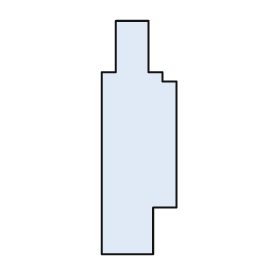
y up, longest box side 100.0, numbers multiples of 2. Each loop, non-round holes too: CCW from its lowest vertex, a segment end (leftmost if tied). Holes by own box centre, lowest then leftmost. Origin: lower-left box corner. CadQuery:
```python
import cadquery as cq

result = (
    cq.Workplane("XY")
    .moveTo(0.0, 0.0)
    .lineTo(22.0, 0.0)
    .lineTo(22.0, 20.0)
    .lineTo(32.0, 20.0)
    .lineTo(32.0, 74.0)
    .lineTo(26.0, 74.0)
    .lineTo(26.0, 78.0)
    .lineTo(20.0, 78.0)
    .lineTo(20.0, 100.0)
    .lineTo(6.0, 100.0)
    .lineTo(6.0, 78.0)
    .lineTo(0.0, 78.0)
    .close()
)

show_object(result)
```